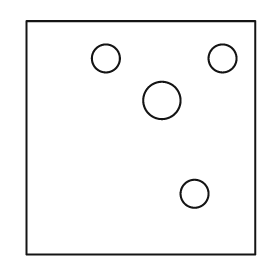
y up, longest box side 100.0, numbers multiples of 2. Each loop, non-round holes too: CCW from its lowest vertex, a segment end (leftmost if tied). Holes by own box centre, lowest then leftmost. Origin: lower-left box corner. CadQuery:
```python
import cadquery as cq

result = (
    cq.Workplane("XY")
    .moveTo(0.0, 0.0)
    .lineTo(98.0, 0.0)
    .lineTo(98.0, 100.0)
    .lineTo(0.0, 100.0)
    .close()
    .moveTo(72.0, 26.0)
    .circle(6.0)
    .moveTo(58.0, 66.0)
    .circle(8.0)
    .moveTo(34.0, 84.0)
    .circle(6.0)
    .moveTo(84.0, 84.0)
    .circle(6.0)
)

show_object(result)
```